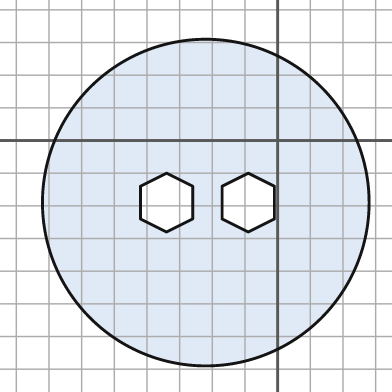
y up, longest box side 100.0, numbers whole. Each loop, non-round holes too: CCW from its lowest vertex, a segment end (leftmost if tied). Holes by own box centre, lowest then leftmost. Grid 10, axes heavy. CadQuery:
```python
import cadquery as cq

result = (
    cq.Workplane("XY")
    .moveTo(-22.0, -19.0)
    .circle(50.0)
    .moveTo(-34.0, -28.0)
    .lineTo(-26.0, -24.0)
    .lineTo(-26.0, -14.0)
    .lineTo(-34.0, -10.0)
    .lineTo(-42.0, -14.0)
    .lineTo(-42.0, -24.0)
    .close()
    .moveTo(-9.0, -28.0)
    .lineTo(-1.0, -24.0)
    .lineTo(-1.0, -14.0)
    .lineTo(-9.0, -10.0)
    .lineTo(-17.0, -14.0)
    .lineTo(-17.0, -24.0)
    .close()
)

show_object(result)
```